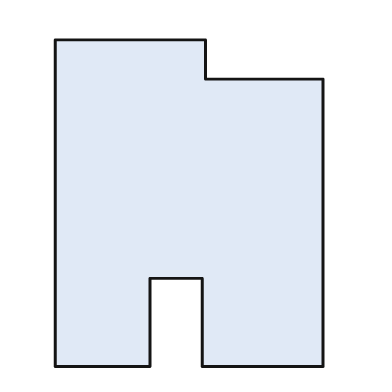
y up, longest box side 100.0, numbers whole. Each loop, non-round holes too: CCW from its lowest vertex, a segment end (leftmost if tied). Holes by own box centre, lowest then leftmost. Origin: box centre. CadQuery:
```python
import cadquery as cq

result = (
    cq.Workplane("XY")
    .moveTo(-41.0, -50.0)
    .lineTo(-12.0, -50.0)
    .lineTo(-12.0, -23.0)
    .lineTo(4.0, -23.0)
    .lineTo(4.0, -50.0)
    .lineTo(41.0, -50.0)
    .lineTo(41.0, 38.0)
    .lineTo(5.0, 38.0)
    .lineTo(5.0, 50.0)
    .lineTo(-41.0, 50.0)
    .close()
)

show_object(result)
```